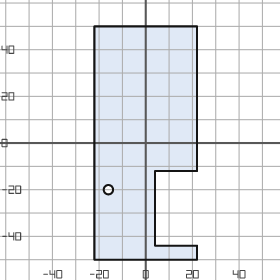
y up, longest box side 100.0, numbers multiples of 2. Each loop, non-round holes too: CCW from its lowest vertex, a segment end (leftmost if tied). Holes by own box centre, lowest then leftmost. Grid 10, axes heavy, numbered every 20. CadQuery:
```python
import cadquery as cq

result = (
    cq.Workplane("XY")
    .moveTo(-22.0, -50.0)
    .lineTo(22.0, -50.0)
    .lineTo(22.0, -44.0)
    .lineTo(4.0, -44.0)
    .lineTo(4.0, -12.0)
    .lineTo(22.0, -12.0)
    .lineTo(22.0, 50.0)
    .lineTo(-22.0, 50.0)
    .close()
    .moveTo(-16.0, -20.0)
    .circle(2.0)
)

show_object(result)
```